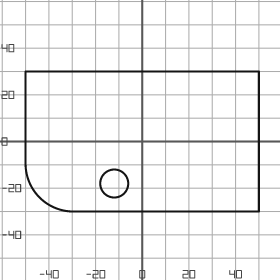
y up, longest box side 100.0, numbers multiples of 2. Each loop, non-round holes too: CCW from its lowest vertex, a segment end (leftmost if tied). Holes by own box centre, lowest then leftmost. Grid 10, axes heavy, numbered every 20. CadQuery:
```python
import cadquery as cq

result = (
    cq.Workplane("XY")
    .moveTo(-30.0, -30.0)
    .lineTo(50.0, -30.0)
    .lineTo(50.0, 30.0)
    .lineTo(-50.0, 30.0)
    .lineTo(-50.0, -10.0)
    .threePointArc((-44.0, -24.0), (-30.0, -30.0))
    .close()
    .moveTo(-12.0, -18.0)
    .circle(6.0)
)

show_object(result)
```